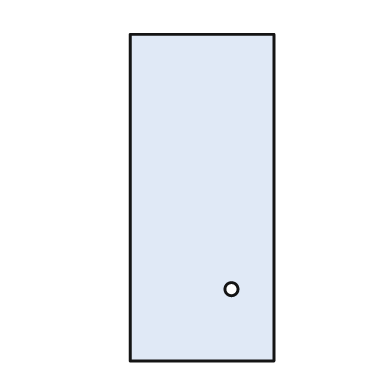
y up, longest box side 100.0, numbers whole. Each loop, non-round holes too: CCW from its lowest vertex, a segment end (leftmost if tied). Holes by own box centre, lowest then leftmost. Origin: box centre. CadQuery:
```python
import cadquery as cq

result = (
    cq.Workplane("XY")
    .moveTo(-22.0, -50.0)
    .lineTo(22.0, -50.0)
    .lineTo(22.0, 50.0)
    .lineTo(-22.0, 50.0)
    .close()
    .moveTo(9.0, -28.0)
    .circle(2.0)
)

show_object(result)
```